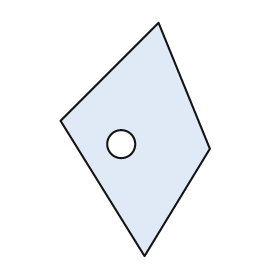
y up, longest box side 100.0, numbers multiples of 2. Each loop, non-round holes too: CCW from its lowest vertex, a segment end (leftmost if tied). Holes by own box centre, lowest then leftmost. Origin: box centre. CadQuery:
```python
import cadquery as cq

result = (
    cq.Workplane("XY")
    .moveTo(4.0, -50.0)
    .lineTo(32.0, -4.0)
    .lineTo(10.0, 50.0)
    .lineTo(-32.0, 8.0)
    .close()
    .moveTo(-6.0, -2.0)
    .circle(6.0)
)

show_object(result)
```